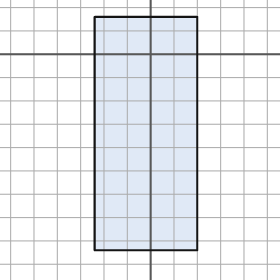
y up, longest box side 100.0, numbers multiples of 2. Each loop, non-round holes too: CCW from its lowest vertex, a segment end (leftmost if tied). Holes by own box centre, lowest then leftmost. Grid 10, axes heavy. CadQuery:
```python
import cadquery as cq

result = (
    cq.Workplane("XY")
    .moveTo(-24.0, -84.0)
    .lineTo(20.0, -84.0)
    .lineTo(20.0, 16.0)
    .lineTo(-24.0, 16.0)
    .close()
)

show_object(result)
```